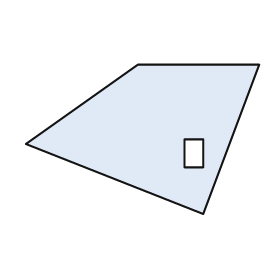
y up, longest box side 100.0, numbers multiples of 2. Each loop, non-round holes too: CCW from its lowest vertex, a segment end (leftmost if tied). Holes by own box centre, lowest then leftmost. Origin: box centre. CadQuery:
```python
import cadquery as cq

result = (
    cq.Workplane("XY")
    .moveTo(26.0, -32.0)
    .lineTo(50.0, 32.0)
    .lineTo(-2.0, 32.0)
    .lineTo(-50.0, -2.0)
    .close()
    .moveTo(18.0, -12.0)
    .lineTo(26.0, -12.0)
    .lineTo(26.0, 0.0)
    .lineTo(18.0, 0.0)
    .close()
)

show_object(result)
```